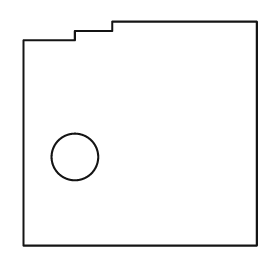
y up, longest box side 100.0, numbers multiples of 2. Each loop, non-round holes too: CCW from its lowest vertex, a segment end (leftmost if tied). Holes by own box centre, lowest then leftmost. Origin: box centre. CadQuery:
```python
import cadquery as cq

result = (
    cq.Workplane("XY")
    .moveTo(-50.0, -48.0)
    .lineTo(50.0, -48.0)
    .lineTo(50.0, 48.0)
    .lineTo(-12.0, 48.0)
    .lineTo(-12.0, 44.0)
    .lineTo(-28.0, 44.0)
    .lineTo(-28.0, 40.0)
    .lineTo(-50.0, 40.0)
    .close()
    .moveTo(-28.0, -10.0)
    .circle(10.0)
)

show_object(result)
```